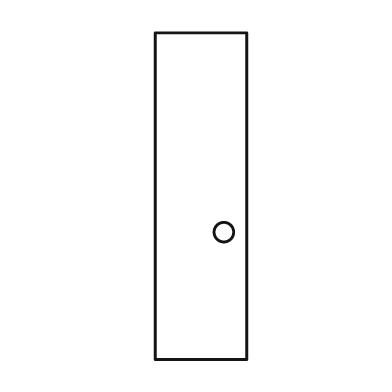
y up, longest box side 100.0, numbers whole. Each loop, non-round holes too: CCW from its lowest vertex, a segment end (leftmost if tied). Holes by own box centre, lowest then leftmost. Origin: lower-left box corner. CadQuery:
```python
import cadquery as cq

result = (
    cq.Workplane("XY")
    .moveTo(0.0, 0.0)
    .lineTo(28.0, 0.0)
    .lineTo(28.0, 100.0)
    .lineTo(0.0, 100.0)
    .close()
    .moveTo(21.0, 39.0)
    .circle(3.0)
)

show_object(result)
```